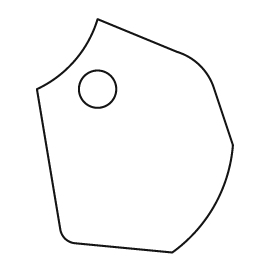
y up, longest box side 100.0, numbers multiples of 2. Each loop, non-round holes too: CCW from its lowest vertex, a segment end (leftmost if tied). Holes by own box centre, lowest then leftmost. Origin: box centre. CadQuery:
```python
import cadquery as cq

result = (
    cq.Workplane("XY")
    .moveTo(16.0, -50.0)
    .threePointArc((34.0, -30.0), (42.0, -4.0))
    .lineTo(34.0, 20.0)
    .threePointArc((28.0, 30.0), (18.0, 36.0))
    .lineTo(-16.0, 50.0)
    .threePointArc((-26.0, 32.0), (-42.0, 20.0))
    .lineTo(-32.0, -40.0)
    .threePointArc((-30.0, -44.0), (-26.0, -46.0))
    .close()
    .moveTo(-16.0, 20.0)
    .circle(8.0)
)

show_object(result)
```